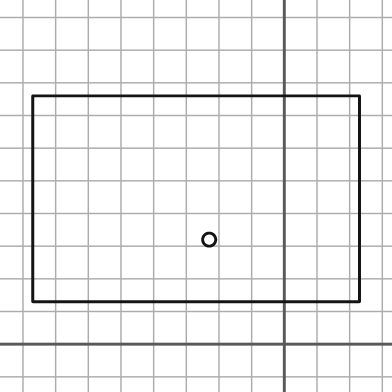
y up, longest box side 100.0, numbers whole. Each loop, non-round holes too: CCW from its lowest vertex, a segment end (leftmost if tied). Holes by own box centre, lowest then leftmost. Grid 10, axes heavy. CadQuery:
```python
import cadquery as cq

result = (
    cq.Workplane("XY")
    .moveTo(-77.0, 13.0)
    .lineTo(23.0, 13.0)
    .lineTo(23.0, 76.0)
    .lineTo(-77.0, 76.0)
    .close()
    .moveTo(-23.0, 32.0)
    .circle(2.0)
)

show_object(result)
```